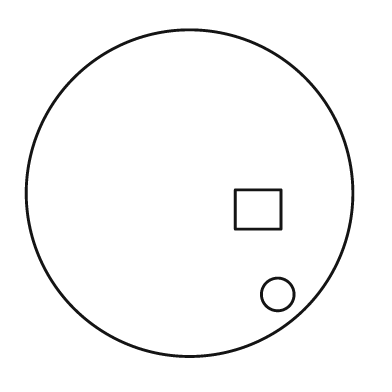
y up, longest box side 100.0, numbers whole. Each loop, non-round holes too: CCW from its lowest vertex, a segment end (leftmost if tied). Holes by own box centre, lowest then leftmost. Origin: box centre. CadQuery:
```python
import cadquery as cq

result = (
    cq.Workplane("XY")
    .moveTo(0.0, 0.0)
    .circle(50.0)
    .moveTo(27.0, -31.0)
    .circle(5.0)
    .moveTo(14.0, -11.0)
    .lineTo(28.0, -11.0)
    .lineTo(28.0, 1.0)
    .lineTo(14.0, 1.0)
    .close()
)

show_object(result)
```